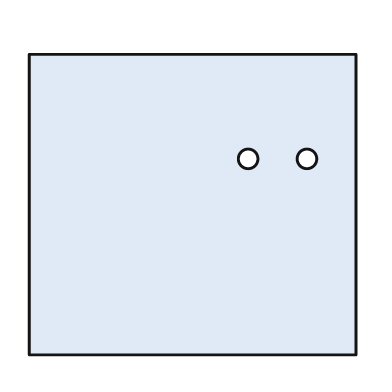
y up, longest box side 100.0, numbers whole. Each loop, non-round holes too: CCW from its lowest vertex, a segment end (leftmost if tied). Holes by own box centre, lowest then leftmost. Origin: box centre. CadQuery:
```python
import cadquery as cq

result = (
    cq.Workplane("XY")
    .moveTo(-50.0, -46.0)
    .lineTo(50.0, -46.0)
    .lineTo(50.0, 46.0)
    .lineTo(-50.0, 46.0)
    .close()
    .moveTo(17.0, 14.0)
    .circle(3.0)
    .moveTo(35.0, 14.0)
    .circle(3.0)
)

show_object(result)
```